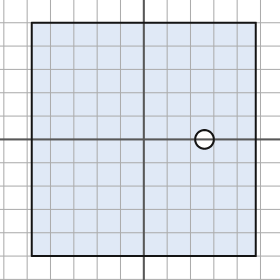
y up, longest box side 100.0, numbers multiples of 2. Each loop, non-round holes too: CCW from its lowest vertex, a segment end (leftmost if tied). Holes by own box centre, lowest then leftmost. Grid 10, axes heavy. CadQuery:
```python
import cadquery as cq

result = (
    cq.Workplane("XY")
    .moveTo(-48.0, -50.0)
    .lineTo(48.0, -50.0)
    .lineTo(48.0, 50.0)
    .lineTo(-48.0, 50.0)
    .close()
    .moveTo(26.0, 0.0)
    .circle(4.0)
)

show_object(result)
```